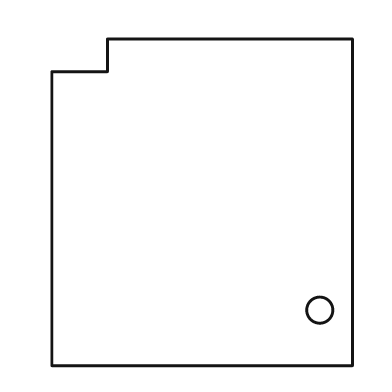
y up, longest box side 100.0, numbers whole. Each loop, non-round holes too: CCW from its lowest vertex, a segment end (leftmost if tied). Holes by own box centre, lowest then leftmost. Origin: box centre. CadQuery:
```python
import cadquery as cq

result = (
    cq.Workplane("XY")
    .moveTo(-46.0, -50.0)
    .lineTo(46.0, -50.0)
    .lineTo(46.0, 50.0)
    .lineTo(-29.0, 50.0)
    .lineTo(-29.0, 40.0)
    .lineTo(-46.0, 40.0)
    .close()
    .moveTo(36.0, -33.0)
    .circle(4.0)
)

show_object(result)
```